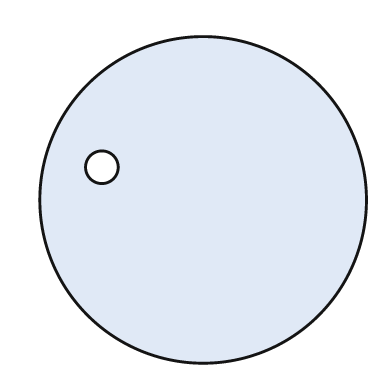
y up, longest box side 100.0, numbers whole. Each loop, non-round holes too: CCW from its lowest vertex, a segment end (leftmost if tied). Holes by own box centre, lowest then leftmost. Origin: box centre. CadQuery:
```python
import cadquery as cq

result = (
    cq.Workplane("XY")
    .moveTo(0.0, 0.0)
    .circle(50.0)
    .moveTo(-31.0, 10.0)
    .circle(5.0)
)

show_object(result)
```